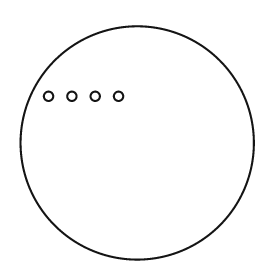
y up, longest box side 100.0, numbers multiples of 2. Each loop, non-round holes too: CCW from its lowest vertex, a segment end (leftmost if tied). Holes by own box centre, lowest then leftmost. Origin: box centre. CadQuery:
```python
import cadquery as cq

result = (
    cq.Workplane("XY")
    .moveTo(0.0, 0.0)
    .circle(50.0)
    .moveTo(-38.0, 20.0)
    .circle(2.0)
    .moveTo(-28.0, 20.0)
    .circle(2.0)
    .moveTo(-18.0, 20.0)
    .circle(2.0)
    .moveTo(-8.0, 20.0)
    .circle(2.0)
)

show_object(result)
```